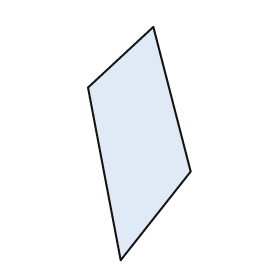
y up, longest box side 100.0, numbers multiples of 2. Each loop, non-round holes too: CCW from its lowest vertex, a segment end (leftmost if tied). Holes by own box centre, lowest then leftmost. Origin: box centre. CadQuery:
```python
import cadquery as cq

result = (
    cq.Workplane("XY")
    .moveTo(-8.0, -50.0)
    .lineTo(22.0, -12.0)
    .lineTo(6.0, 50.0)
    .lineTo(-22.0, 24.0)
    .close()
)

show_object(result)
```